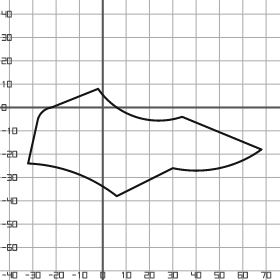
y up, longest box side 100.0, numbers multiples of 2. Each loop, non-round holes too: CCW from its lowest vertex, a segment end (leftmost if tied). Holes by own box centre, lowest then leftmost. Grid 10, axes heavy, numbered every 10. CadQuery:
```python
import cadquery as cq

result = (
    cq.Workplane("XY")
    .moveTo(6.0, -38.0)
    .lineTo(30.0, -26.0)
    .threePointArc((50.0, -26.0), (68.0, -18.0))
    .lineTo(34.0, -4.0)
    .threePointArc((14.0, -4.0), (-2.0, 8.0))
    .lineTo(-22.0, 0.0)
    .threePointArc((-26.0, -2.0), (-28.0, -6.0))
    .lineTo(-32.0, -24.0)
    .threePointArc((-12.0, -28.0), (6.0, -38.0))
    .close()
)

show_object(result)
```